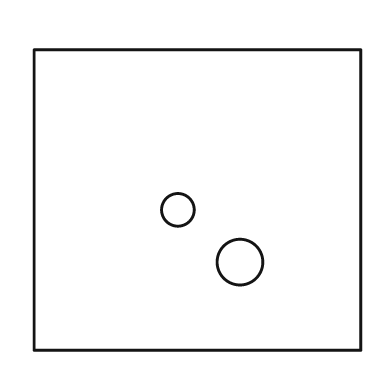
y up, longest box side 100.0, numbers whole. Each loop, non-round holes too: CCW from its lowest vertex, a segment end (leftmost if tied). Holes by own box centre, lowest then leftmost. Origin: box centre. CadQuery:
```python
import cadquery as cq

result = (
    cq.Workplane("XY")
    .moveTo(-50.0, -46.0)
    .lineTo(50.0, -46.0)
    .lineTo(50.0, 46.0)
    .lineTo(-50.0, 46.0)
    .close()
    .moveTo(13.0, -19.0)
    .circle(7.0)
    .moveTo(-6.0, -3.0)
    .circle(5.0)
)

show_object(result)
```